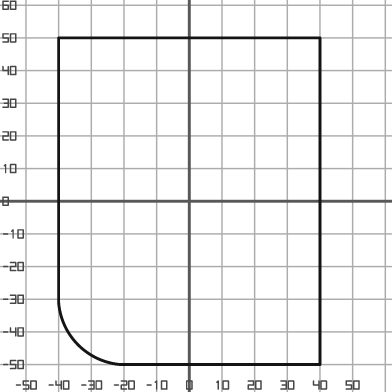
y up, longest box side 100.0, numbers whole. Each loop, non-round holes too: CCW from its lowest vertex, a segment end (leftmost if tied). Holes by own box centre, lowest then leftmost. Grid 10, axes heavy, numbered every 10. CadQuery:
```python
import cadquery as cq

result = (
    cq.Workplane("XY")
    .moveTo(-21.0, -50.0)
    .lineTo(40.0, -50.0)
    .lineTo(40.0, 50.0)
    .lineTo(-40.0, 50.0)
    .lineTo(-40.0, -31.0)
    .threePointArc((-34.0, -44.0), (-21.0, -50.0))
    .close()
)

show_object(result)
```